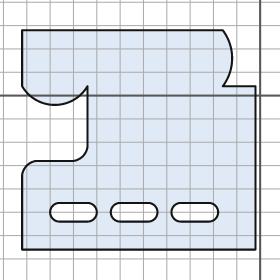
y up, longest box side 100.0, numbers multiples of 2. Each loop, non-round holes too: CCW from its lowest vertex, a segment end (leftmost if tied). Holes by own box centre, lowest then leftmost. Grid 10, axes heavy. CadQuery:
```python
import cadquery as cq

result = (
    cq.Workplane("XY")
    .moveTo(-102.0, -66.0)
    .lineTo(-2.0, -66.0)
    .lineTo(-2.0, 4.0)
    .lineTo(-16.0, 4.0)
    .threePointArc((-12.0, 16.0), (-16.0, 28.0))
    .lineTo(-102.0, 28.0)
    .lineTo(-102.0, 4.0)
    .threePointArc((-88.0, -4.0), (-74.0, 4.0))
    .lineTo(-74.0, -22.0)
    .threePointArc((-76.0, -26.0), (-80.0, -28.0))
    .lineTo(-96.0, -28.0)
    .threePointArc((-100.0, -30.0), (-102.0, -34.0))
    .close()
    .moveTo(-86.0, -54.0)
    .lineTo(-74.0, -54.0)
    .threePointArc((-70.0, -50.0), (-74.0, -46.0))
    .lineTo(-86.0, -46.0)
    .threePointArc((-90.0, -50.0), (-86.0, -54.0))
    .close()
    .moveTo(-60.0, -54.0)
    .lineTo(-48.0, -54.0)
    .threePointArc((-44.0, -50.0), (-48.0, -46.0))
    .lineTo(-60.0, -46.0)
    .threePointArc((-64.0, -50.0), (-60.0, -54.0))
    .close()
    .moveTo(-34.0, -54.0)
    .lineTo(-22.0, -54.0)
    .threePointArc((-18.0, -50.0), (-22.0, -46.0))
    .lineTo(-34.0, -46.0)
    .threePointArc((-38.0, -50.0), (-34.0, -54.0))
    .close()
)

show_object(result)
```